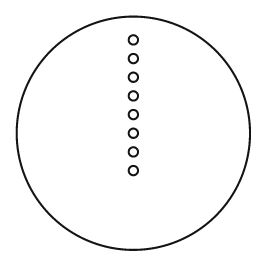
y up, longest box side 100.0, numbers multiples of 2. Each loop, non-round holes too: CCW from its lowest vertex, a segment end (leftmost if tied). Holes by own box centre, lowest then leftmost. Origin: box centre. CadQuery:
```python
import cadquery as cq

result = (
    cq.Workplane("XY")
    .moveTo(0.0, 0.0)
    .circle(50.0)
    .moveTo(0.0, -16.0)
    .circle(2.0)
    .moveTo(0.0, -8.0)
    .circle(2.0)
    .moveTo(0.0, 0.0)
    .circle(2.0)
    .moveTo(0.0, 8.0)
    .circle(2.0)
    .moveTo(0.0, 16.0)
    .circle(2.0)
    .moveTo(0.0, 24.0)
    .circle(2.0)
    .moveTo(0.0, 32.0)
    .circle(2.0)
    .moveTo(0.0, 40.0)
    .circle(2.0)
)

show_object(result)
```